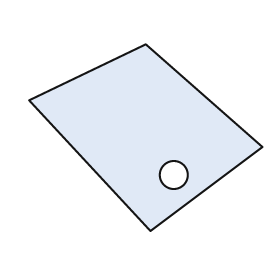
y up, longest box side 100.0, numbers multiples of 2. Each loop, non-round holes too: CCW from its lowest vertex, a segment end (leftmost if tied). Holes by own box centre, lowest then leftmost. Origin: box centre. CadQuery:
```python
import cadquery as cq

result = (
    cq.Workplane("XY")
    .moveTo(2.0, -40.0)
    .lineTo(50.0, -4.0)
    .lineTo(0.0, 40.0)
    .lineTo(-50.0, 16.0)
    .close()
    .moveTo(12.0, -16.0)
    .circle(6.0)
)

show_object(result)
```